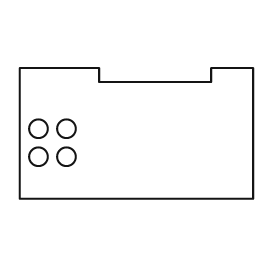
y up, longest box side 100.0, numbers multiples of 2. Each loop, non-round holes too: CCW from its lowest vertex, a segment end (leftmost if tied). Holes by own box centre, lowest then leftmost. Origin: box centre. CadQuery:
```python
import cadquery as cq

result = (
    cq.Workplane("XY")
    .moveTo(-50.0, -28.0)
    .lineTo(50.0, -28.0)
    .lineTo(50.0, 28.0)
    .lineTo(32.0, 28.0)
    .lineTo(32.0, 22.0)
    .lineTo(-16.0, 22.0)
    .lineTo(-16.0, 28.0)
    .lineTo(-50.0, 28.0)
    .close()
    .moveTo(-42.0, -10.0)
    .circle(4.0)
    .moveTo(-30.0, -10.0)
    .circle(4.0)
    .moveTo(-42.0, 2.0)
    .circle(4.0)
    .moveTo(-30.0, 2.0)
    .circle(4.0)
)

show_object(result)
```